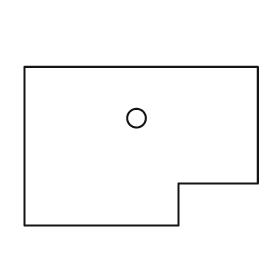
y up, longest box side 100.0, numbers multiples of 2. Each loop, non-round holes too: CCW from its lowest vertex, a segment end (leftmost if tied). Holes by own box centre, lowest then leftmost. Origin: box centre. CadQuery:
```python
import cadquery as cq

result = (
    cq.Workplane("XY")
    .moveTo(-50.0, -34.0)
    .lineTo(16.0, -34.0)
    .lineTo(16.0, -16.0)
    .lineTo(50.0, -16.0)
    .lineTo(50.0, 34.0)
    .lineTo(-50.0, 34.0)
    .close()
    .moveTo(-2.0, 12.0)
    .circle(4.0)
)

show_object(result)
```